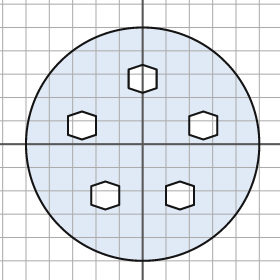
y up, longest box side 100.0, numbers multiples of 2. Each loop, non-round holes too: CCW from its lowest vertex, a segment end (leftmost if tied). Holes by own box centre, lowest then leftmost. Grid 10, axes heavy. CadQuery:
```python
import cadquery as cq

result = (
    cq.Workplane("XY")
    .moveTo(0.0, 0.0)
    .circle(50.0)
    .moveTo(-16.0, -28.0)
    .lineTo(-10.0, -26.0)
    .lineTo(-10.0, -18.0)
    .lineTo(-16.0, -16.0)
    .lineTo(-22.0, -18.0)
    .lineTo(-22.0, -26.0)
    .close()
    .moveTo(16.0, -28.0)
    .lineTo(22.0, -26.0)
    .lineTo(22.0, -18.0)
    .lineTo(16.0, -16.0)
    .lineTo(10.0, -18.0)
    .lineTo(10.0, -26.0)
    .close()
    .moveTo(-26.0, 2.0)
    .lineTo(-20.0, 4.0)
    .lineTo(-20.0, 12.0)
    .lineTo(-26.0, 14.0)
    .lineTo(-32.0, 12.0)
    .lineTo(-32.0, 4.0)
    .close()
    .moveTo(26.0, 2.0)
    .lineTo(32.0, 4.0)
    .lineTo(32.0, 12.0)
    .lineTo(26.0, 14.0)
    .lineTo(20.0, 12.0)
    .lineTo(20.0, 4.0)
    .close()
    .moveTo(0.0, 22.0)
    .lineTo(6.0, 24.0)
    .lineTo(6.0, 32.0)
    .lineTo(0.0, 34.0)
    .lineTo(-6.0, 32.0)
    .lineTo(-6.0, 24.0)
    .close()
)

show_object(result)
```